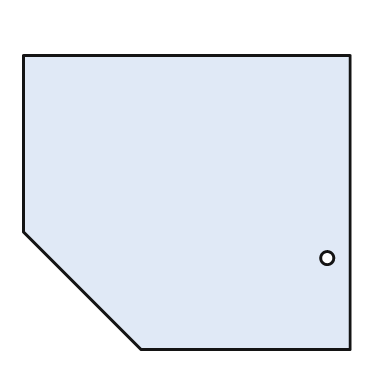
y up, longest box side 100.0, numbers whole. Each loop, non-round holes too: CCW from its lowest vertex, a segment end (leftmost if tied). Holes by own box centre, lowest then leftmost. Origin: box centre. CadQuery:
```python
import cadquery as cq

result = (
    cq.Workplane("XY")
    .moveTo(-14.0, -45.0)
    .lineTo(50.0, -45.0)
    .lineTo(50.0, 45.0)
    .lineTo(-50.0, 45.0)
    .lineTo(-50.0, -9.0)
    .close()
    .moveTo(43.0, -17.0)
    .circle(2.0)
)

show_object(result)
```